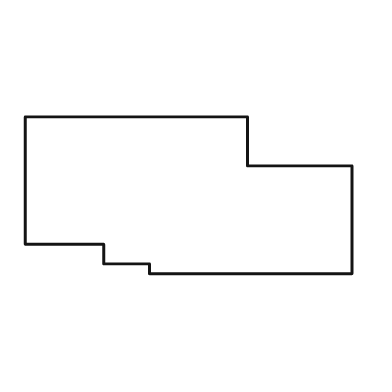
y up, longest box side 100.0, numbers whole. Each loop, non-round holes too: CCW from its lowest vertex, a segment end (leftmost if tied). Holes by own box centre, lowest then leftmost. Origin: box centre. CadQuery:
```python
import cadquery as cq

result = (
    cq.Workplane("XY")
    .moveTo(-12.0, -24.0)
    .lineTo(50.0, -24.0)
    .lineTo(50.0, 9.0)
    .lineTo(18.0, 9.0)
    .lineTo(18.0, 24.0)
    .lineTo(-50.0, 24.0)
    .lineTo(-50.0, -15.0)
    .lineTo(-26.0, -15.0)
    .lineTo(-26.0, -21.0)
    .lineTo(-12.0, -21.0)
    .close()
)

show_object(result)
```